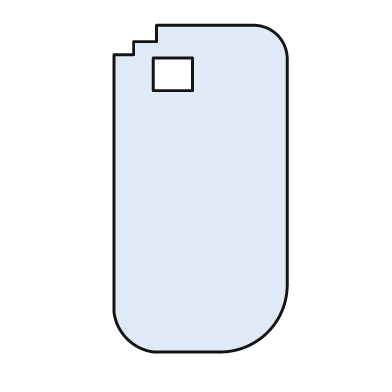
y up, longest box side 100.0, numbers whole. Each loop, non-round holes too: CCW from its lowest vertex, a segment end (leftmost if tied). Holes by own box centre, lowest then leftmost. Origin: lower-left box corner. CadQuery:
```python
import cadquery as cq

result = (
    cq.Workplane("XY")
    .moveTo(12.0, 0.0)
    .lineTo(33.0, 0.0)
    .threePointArc((47.0, 6.0), (53.0, 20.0))
    .lineTo(53.0, 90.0)
    .threePointArc((50.0, 97.0), (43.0, 100.0))
    .lineTo(13.0, 100.0)
    .lineTo(13.0, 95.0)
    .lineTo(6.0, 95.0)
    .lineTo(6.0, 91.0)
    .lineTo(0.0, 91.0)
    .lineTo(0.0, 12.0)
    .threePointArc((4.0, 4.0), (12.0, 0.0))
    .close()
    .moveTo(12.0, 80.0)
    .lineTo(24.0, 80.0)
    .lineTo(24.0, 90.0)
    .lineTo(12.0, 90.0)
    .close()
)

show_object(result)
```